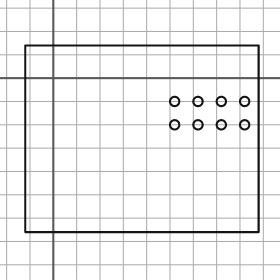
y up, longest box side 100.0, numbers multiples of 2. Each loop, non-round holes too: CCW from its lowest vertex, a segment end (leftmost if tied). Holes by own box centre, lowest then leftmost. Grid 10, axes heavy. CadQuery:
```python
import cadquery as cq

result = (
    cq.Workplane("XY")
    .moveTo(-12.0, -66.0)
    .lineTo(88.0, -66.0)
    .lineTo(88.0, 14.0)
    .lineTo(-12.0, 14.0)
    .close()
    .moveTo(52.0, -20.0)
    .circle(2.0)
    .moveTo(62.0, -20.0)
    .circle(2.0)
    .moveTo(72.0, -20.0)
    .circle(2.0)
    .moveTo(82.0, -20.0)
    .circle(2.0)
    .moveTo(52.0, -10.0)
    .circle(2.0)
    .moveTo(62.0, -10.0)
    .circle(2.0)
    .moveTo(72.0, -10.0)
    .circle(2.0)
    .moveTo(82.0, -10.0)
    .circle(2.0)
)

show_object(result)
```